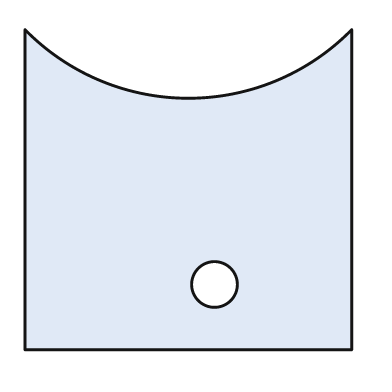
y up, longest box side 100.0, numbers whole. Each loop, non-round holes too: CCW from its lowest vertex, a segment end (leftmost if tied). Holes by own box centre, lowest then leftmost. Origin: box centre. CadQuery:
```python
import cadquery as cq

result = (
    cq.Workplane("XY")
    .moveTo(-50.0, -49.0)
    .lineTo(50.0, -49.0)
    .lineTo(50.0, 49.0)
    .threePointArc((0.0, 28.0), (-50.0, 49.0))
    .close()
    .moveTo(8.0, -29.0)
    .circle(7.0)
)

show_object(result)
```